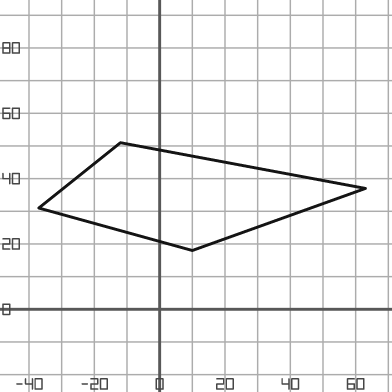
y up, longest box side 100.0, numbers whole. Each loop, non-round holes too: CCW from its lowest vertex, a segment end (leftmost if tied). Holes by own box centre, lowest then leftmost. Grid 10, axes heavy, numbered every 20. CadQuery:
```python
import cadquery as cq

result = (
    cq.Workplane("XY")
    .moveTo(10.0, 18.0)
    .lineTo(63.0, 37.0)
    .lineTo(-12.0, 51.0)
    .lineTo(-37.0, 31.0)
    .close()
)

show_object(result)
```